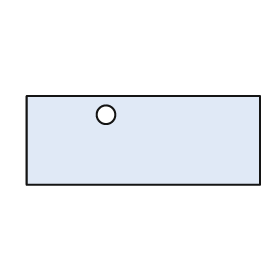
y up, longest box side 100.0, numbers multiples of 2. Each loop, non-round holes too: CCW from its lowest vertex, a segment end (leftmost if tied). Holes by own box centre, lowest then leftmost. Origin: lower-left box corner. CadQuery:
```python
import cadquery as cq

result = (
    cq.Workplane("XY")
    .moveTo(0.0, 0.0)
    .lineTo(100.0, 0.0)
    .lineTo(100.0, 38.0)
    .lineTo(0.0, 38.0)
    .close()
    .moveTo(34.0, 30.0)
    .circle(4.0)
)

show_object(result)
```